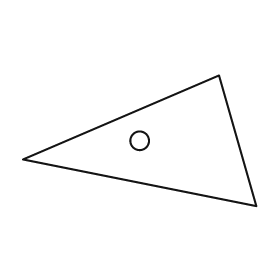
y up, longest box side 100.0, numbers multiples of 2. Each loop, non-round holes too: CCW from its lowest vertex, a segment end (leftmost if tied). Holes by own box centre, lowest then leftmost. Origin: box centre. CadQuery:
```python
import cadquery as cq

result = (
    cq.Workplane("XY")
    .moveTo(50.0, -28.0)
    .lineTo(34.0, 28.0)
    .lineTo(-50.0, -8.0)
    .close()
    .moveTo(0.0, 0.0)
    .circle(4.0)
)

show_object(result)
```